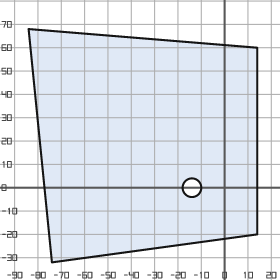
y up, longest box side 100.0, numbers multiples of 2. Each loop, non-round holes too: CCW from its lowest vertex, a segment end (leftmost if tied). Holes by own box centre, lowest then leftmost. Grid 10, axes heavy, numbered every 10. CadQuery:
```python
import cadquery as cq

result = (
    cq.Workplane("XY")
    .moveTo(-74.0, -32.0)
    .lineTo(14.0, -20.0)
    .lineTo(14.0, 60.0)
    .lineTo(-84.0, 68.0)
    .close()
    .moveTo(-14.0, 0.0)
    .circle(4.0)
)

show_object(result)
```